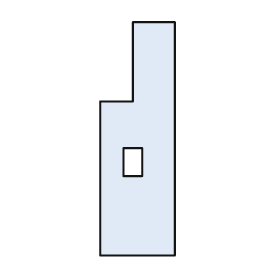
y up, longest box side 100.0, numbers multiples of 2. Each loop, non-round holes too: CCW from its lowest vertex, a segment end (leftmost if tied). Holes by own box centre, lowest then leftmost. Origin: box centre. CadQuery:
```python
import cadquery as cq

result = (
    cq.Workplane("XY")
    .moveTo(-16.0, -50.0)
    .lineTo(16.0, -50.0)
    .lineTo(16.0, 50.0)
    .lineTo(-2.0, 50.0)
    .lineTo(-2.0, 16.0)
    .lineTo(-16.0, 16.0)
    .close()
    .moveTo(-6.0, -16.0)
    .lineTo(2.0, -16.0)
    .lineTo(2.0, -4.0)
    .lineTo(-6.0, -4.0)
    .close()
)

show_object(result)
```